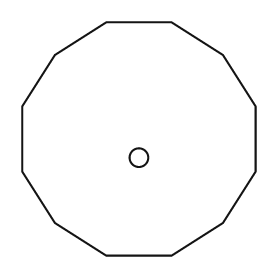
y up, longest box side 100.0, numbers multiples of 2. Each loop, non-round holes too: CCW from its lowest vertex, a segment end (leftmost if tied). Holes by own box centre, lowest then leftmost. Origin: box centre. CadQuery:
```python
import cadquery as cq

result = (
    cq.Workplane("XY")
    .moveTo(-14.0, -50.0)
    .lineTo(14.0, -50.0)
    .lineTo(36.0, -36.0)
    .lineTo(50.0, -14.0)
    .lineTo(50.0, 14.0)
    .lineTo(36.0, 36.0)
    .lineTo(14.0, 50.0)
    .lineTo(-14.0, 50.0)
    .lineTo(-36.0, 36.0)
    .lineTo(-50.0, 14.0)
    .lineTo(-50.0, -14.0)
    .lineTo(-36.0, -36.0)
    .close()
    .moveTo(0.0, -8.0)
    .circle(4.0)
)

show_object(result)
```